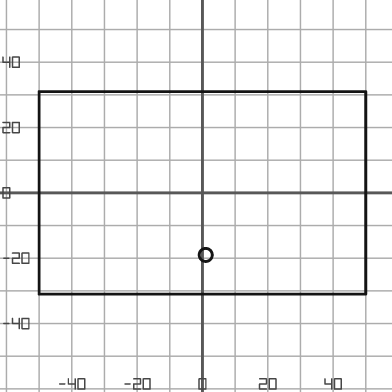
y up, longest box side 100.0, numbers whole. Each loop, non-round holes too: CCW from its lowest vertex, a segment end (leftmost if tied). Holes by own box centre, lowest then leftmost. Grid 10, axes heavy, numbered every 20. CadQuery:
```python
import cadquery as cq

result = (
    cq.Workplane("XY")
    .moveTo(-50.0, -31.0)
    .lineTo(50.0, -31.0)
    .lineTo(50.0, 31.0)
    .lineTo(-50.0, 31.0)
    .close()
    .moveTo(1.0, -19.0)
    .circle(2.0)
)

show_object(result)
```